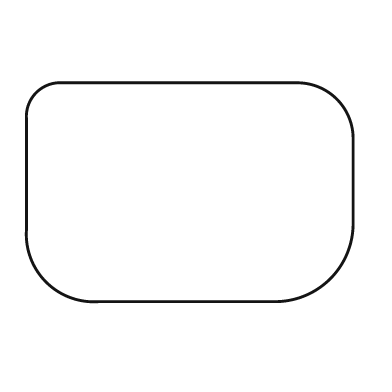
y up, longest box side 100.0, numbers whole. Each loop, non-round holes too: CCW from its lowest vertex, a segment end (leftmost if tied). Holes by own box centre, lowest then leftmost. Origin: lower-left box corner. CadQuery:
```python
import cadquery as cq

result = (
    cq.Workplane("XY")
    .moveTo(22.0, 0.0)
    .lineTo(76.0, 0.0)
    .threePointArc((93.0, 7.0), (100.0, 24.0))
    .lineTo(100.0, 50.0)
    .threePointArc((95.0, 62.0), (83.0, 67.0))
    .lineTo(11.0, 67.0)
    .threePointArc((3.0, 64.0), (0.0, 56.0))
    .lineTo(0.0, 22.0)
    .threePointArc((6.0, 6.0), (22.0, 0.0))
    .close()
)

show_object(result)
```